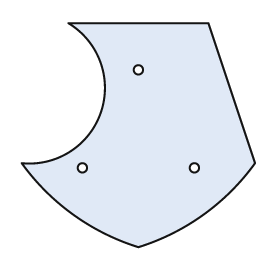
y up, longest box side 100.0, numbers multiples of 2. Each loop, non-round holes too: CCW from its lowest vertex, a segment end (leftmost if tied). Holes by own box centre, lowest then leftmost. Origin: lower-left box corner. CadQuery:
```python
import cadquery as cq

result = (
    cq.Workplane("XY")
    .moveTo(50.0, 0.0)
    .threePointArc((78.0, 14.0), (100.0, 36.0))
    .lineTo(80.0, 96.0)
    .lineTo(20.0, 96.0)
    .threePointArc((34.0, 58.0), (0.0, 36.0))
    .threePointArc((22.0, 14.0), (50.0, 0.0))
    .close()
    .moveTo(26.0, 34.0)
    .circle(2.0)
    .moveTo(74.0, 34.0)
    .circle(2.0)
    .moveTo(50.0, 76.0)
    .circle(2.0)
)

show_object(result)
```